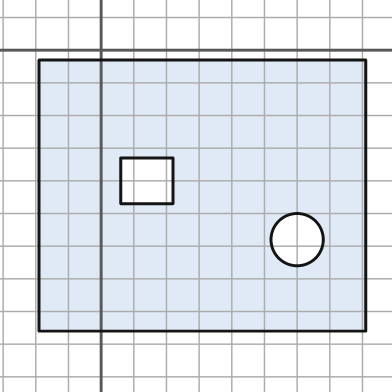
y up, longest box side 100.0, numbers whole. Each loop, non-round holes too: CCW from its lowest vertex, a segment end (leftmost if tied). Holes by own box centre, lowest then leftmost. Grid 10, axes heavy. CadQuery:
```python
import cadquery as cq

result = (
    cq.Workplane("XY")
    .moveTo(-19.0, -86.0)
    .lineTo(81.0, -86.0)
    .lineTo(81.0, -3.0)
    .lineTo(-19.0, -3.0)
    .close()
    .moveTo(60.0, -58.0)
    .circle(8.0)
    .moveTo(6.0, -47.0)
    .lineTo(22.0, -47.0)
    .lineTo(22.0, -33.0)
    .lineTo(6.0, -33.0)
    .close()
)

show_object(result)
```